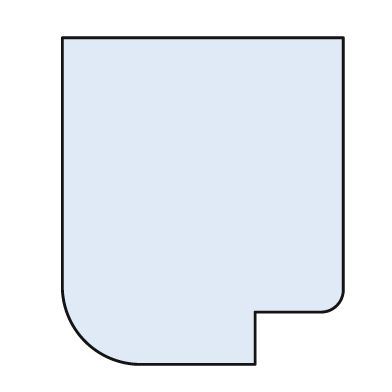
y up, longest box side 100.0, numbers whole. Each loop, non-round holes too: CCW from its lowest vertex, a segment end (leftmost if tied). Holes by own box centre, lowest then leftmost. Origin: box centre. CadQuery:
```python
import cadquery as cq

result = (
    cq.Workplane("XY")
    .moveTo(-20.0, -50.0)
    .lineTo(16.0, -50.0)
    .lineTo(16.0, -34.0)
    .lineTo(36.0, -34.0)
    .threePointArc((41.0, -32.0), (43.0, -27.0))
    .lineTo(43.0, 50.0)
    .lineTo(-43.0, 50.0)
    .lineTo(-43.0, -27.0)
    .threePointArc((-36.0, -43.0), (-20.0, -50.0))
    .close()
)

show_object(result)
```